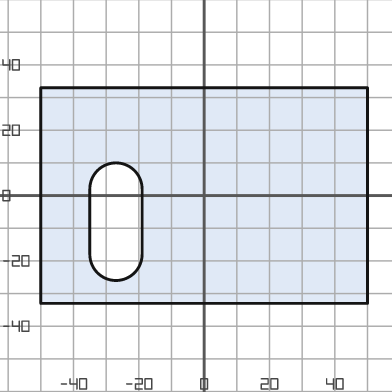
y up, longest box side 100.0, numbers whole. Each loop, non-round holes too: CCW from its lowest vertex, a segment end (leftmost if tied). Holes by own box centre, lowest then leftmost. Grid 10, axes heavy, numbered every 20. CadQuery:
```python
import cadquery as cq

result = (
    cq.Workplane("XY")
    .moveTo(-50.0, -33.0)
    .lineTo(50.0, -33.0)
    .lineTo(50.0, 33.0)
    .lineTo(-50.0, 33.0)
    .close()
    .moveTo(-35.0, -18.0)
    .threePointArc((-27.0, -26.0), (-19.0, -18.0))
    .lineTo(-19.0, 2.0)
    .threePointArc((-27.0, 10.0), (-35.0, 2.0))
    .close()
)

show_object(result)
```